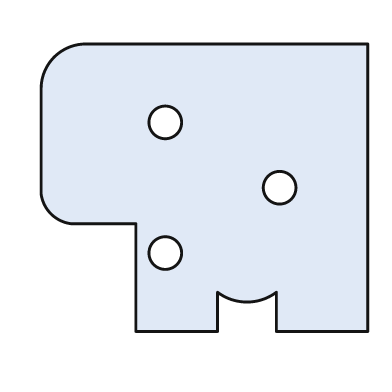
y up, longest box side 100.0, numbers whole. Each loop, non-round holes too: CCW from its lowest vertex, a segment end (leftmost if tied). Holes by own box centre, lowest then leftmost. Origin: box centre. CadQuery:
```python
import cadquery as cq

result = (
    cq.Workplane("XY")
    .moveTo(-21.0, -44.0)
    .lineTo(4.0, -44.0)
    .lineTo(4.0, -32.0)
    .threePointArc((13.0, -35.0), (22.0, -32.0))
    .lineTo(22.0, -44.0)
    .lineTo(50.0, -44.0)
    .lineTo(50.0, 44.0)
    .lineTo(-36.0, 44.0)
    .threePointArc((-46.0, 40.0), (-50.0, 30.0))
    .lineTo(-50.0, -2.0)
    .threePointArc((-47.0, -8.0), (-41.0, -11.0))
    .lineTo(-21.0, -11.0)
    .close()
    .moveTo(-12.0, -20.0)
    .circle(5.0)
    .moveTo(23.0, 0.0)
    .circle(5.0)
    .moveTo(-12.0, 20.0)
    .circle(5.0)
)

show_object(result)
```